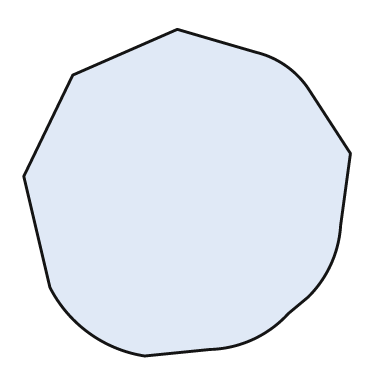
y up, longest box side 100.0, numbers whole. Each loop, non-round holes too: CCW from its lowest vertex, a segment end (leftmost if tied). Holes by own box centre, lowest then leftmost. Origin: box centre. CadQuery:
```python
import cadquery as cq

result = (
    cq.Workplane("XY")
    .moveTo(-13.0, -50.0)
    .lineTo(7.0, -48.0)
    .threePointArc((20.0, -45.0), (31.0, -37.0))
    .lineTo(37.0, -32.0)
    .threePointArc((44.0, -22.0), (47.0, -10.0))
    .lineTo(50.0, 12.0)
    .lineTo(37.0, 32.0)
    .threePointArc((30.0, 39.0), (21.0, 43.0))
    .lineTo(-3.0, 50.0)
    .lineTo(-35.0, 36.0)
    .lineTo(-50.0, 5.0)
    .lineTo(-42.0, -29.0)
    .threePointArc((-30.0, -43.0), (-13.0, -50.0))
    .close()
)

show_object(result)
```